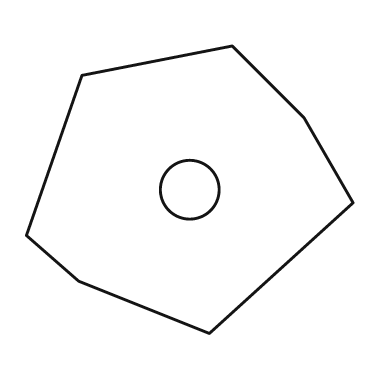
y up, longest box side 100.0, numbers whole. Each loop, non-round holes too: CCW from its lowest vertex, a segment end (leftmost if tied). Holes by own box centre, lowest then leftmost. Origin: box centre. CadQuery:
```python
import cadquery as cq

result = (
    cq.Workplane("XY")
    .moveTo(6.0, -44.0)
    .lineTo(50.0, -4.0)
    .lineTo(35.0, 22.0)
    .lineTo(13.0, 44.0)
    .lineTo(-33.0, 35.0)
    .lineTo(-50.0, -14.0)
    .lineTo(-34.0, -28.0)
    .close()
    .moveTo(0.0, 0.0)
    .circle(9.0)
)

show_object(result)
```